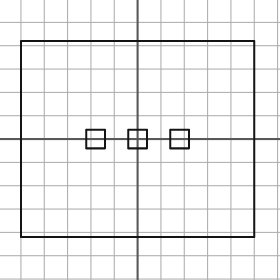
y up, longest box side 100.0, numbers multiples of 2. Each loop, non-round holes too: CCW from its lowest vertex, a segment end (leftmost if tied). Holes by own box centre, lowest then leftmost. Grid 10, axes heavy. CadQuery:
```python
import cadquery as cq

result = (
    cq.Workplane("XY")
    .moveTo(-50.0, -42.0)
    .lineTo(50.0, -42.0)
    .lineTo(50.0, 42.0)
    .lineTo(-50.0, 42.0)
    .close()
    .moveTo(-22.0, -4.0)
    .lineTo(-14.0, -4.0)
    .lineTo(-14.0, 4.0)
    .lineTo(-22.0, 4.0)
    .close()
    .moveTo(-4.0, -4.0)
    .lineTo(4.0, -4.0)
    .lineTo(4.0, 4.0)
    .lineTo(-4.0, 4.0)
    .close()
    .moveTo(14.0, -4.0)
    .lineTo(22.0, -4.0)
    .lineTo(22.0, 4.0)
    .lineTo(14.0, 4.0)
    .close()
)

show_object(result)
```